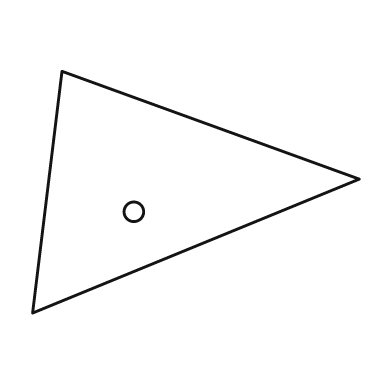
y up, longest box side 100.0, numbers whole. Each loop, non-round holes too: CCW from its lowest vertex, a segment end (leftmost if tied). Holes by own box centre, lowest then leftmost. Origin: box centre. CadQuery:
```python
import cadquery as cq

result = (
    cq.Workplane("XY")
    .moveTo(-50.0, -37.0)
    .lineTo(50.0, 4.0)
    .lineTo(-41.0, 37.0)
    .close()
    .moveTo(-19.0, -6.0)
    .circle(3.0)
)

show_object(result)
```